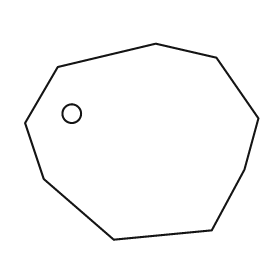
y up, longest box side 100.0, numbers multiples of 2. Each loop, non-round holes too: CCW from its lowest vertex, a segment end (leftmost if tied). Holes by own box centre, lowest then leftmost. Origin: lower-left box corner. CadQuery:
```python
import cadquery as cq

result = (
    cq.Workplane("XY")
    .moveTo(38.0, 0.0)
    .lineTo(80.0, 4.0)
    .lineTo(94.0, 30.0)
    .lineTo(100.0, 52.0)
    .lineTo(82.0, 78.0)
    .lineTo(56.0, 84.0)
    .lineTo(14.0, 74.0)
    .lineTo(0.0, 50.0)
    .lineTo(8.0, 26.0)
    .close()
    .moveTo(20.0, 54.0)
    .circle(4.0)
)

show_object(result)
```